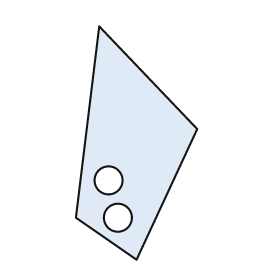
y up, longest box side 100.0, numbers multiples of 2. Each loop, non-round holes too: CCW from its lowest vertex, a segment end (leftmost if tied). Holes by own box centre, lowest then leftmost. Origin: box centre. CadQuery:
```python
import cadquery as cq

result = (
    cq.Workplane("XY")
    .moveTo(0.0, -50.0)
    .lineTo(26.0, 6.0)
    .lineTo(-16.0, 50.0)
    .lineTo(-26.0, -32.0)
    .close()
    .moveTo(-8.0, -32.0)
    .circle(6.0)
    .moveTo(-12.0, -16.0)
    .circle(6.0)
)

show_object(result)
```